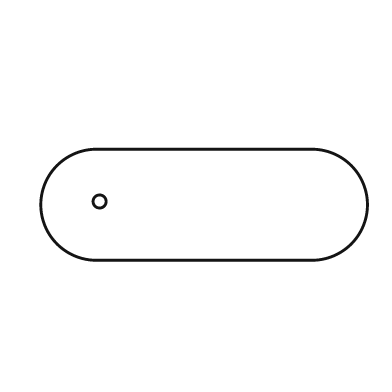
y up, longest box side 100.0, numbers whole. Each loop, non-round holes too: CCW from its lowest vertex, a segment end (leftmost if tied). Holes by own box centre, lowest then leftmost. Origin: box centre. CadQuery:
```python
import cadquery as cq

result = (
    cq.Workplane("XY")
    .moveTo(-33.0, -17.0)
    .lineTo(33.0, -17.0)
    .threePointArc((50.0, 0.0), (33.0, 17.0))
    .lineTo(-33.0, 17.0)
    .threePointArc((-50.0, 0.0), (-33.0, -17.0))
    .close()
    .moveTo(-32.0, 1.0)
    .circle(2.0)
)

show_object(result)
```